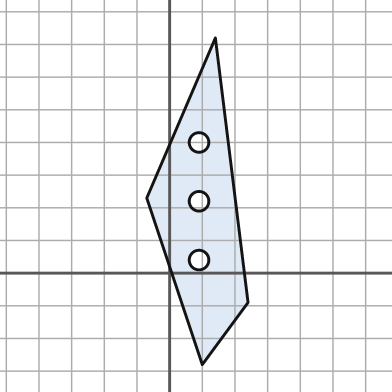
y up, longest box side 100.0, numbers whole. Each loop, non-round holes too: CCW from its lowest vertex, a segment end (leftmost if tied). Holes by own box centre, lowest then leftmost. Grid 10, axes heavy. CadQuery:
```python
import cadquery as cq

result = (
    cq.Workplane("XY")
    .moveTo(10.0, -28.0)
    .lineTo(24.0, -9.0)
    .lineTo(14.0, 72.0)
    .lineTo(-7.0, 23.0)
    .close()
    .moveTo(9.0, 4.0)
    .circle(3.0)
    .moveTo(9.0, 22.0)
    .circle(3.0)
    .moveTo(9.0, 40.0)
    .circle(3.0)
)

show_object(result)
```